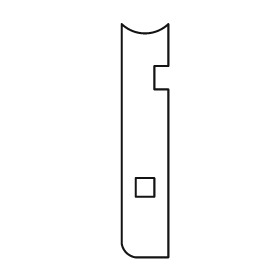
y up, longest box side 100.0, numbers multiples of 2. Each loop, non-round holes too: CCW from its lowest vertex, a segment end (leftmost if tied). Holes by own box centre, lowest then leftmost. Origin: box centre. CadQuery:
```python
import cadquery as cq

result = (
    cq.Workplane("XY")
    .moveTo(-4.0, -50.0)
    .lineTo(10.0, -50.0)
    .lineTo(10.0, 22.0)
    .lineTo(4.0, 22.0)
    .lineTo(4.0, 32.0)
    .lineTo(10.0, 32.0)
    .lineTo(10.0, 50.0)
    .threePointArc((0.0, 46.0), (-10.0, 50.0))
    .lineTo(-10.0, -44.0)
    .threePointArc((-8.0, -48.0), (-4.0, -50.0))
    .close()
    .moveTo(-4.0, -24.0)
    .lineTo(4.0, -24.0)
    .lineTo(4.0, -16.0)
    .lineTo(-4.0, -16.0)
    .close()
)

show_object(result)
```